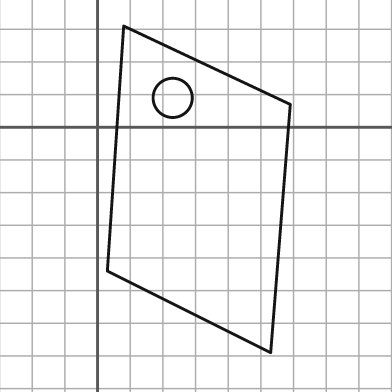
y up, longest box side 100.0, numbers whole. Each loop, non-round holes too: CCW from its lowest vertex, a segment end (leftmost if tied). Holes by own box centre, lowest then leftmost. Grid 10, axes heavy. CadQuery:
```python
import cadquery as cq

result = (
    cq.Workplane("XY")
    .moveTo(53.0, -69.0)
    .lineTo(59.0, 7.0)
    .lineTo(8.0, 31.0)
    .lineTo(3.0, -44.0)
    .close()
    .moveTo(23.0, 9.0)
    .circle(6.0)
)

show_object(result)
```